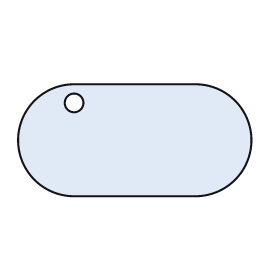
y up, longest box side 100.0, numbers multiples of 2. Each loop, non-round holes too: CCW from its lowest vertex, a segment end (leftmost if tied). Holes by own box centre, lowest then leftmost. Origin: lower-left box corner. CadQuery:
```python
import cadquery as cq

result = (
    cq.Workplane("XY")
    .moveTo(24.0, 0.0)
    .lineTo(76.0, 0.0)
    .threePointArc((100.0, 24.0), (76.0, 48.0))
    .lineTo(24.0, 48.0)
    .threePointArc((0.0, 24.0), (24.0, 0.0))
    .close()
    .moveTo(24.0, 40.0)
    .circle(4.0)
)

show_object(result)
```